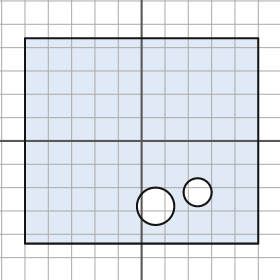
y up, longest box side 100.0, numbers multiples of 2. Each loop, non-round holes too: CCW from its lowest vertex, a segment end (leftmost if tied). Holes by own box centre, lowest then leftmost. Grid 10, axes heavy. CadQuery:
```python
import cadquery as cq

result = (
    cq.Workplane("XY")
    .moveTo(-50.0, -44.0)
    .lineTo(50.0, -44.0)
    .lineTo(50.0, 44.0)
    .lineTo(-50.0, 44.0)
    .close()
    .moveTo(6.0, -28.0)
    .circle(8.0)
    .moveTo(24.0, -22.0)
    .circle(6.0)
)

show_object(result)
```